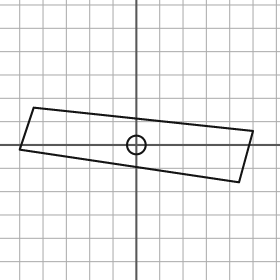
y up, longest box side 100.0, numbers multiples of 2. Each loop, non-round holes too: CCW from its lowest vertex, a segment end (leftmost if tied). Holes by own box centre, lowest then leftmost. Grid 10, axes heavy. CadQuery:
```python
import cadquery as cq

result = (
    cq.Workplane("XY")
    .moveTo(44.0, -16.0)
    .lineTo(50.0, 6.0)
    .lineTo(-44.0, 16.0)
    .lineTo(-50.0, -2.0)
    .close()
    .moveTo(0.0, 0.0)
    .circle(4.0)
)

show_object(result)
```